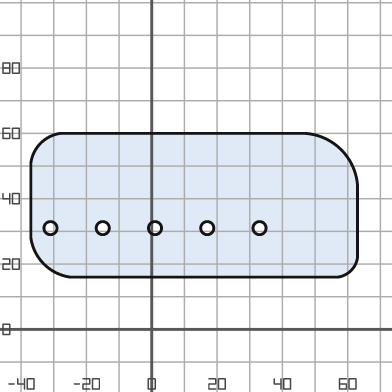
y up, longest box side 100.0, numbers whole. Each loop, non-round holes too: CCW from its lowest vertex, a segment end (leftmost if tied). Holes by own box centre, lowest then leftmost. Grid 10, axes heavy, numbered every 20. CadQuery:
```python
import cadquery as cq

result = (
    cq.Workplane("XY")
    .moveTo(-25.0, 16.0)
    .lineTo(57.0, 16.0)
    .threePointArc((61.0, 18.0), (63.0, 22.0))
    .lineTo(63.0, 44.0)
    .threePointArc((58.0, 55.0), (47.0, 60.0))
    .lineTo(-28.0, 60.0)
    .threePointArc((-34.0, 57.0), (-37.0, 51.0))
    .lineTo(-37.0, 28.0)
    .threePointArc((-33.0, 20.0), (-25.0, 16.0))
    .close()
    .moveTo(-31.0, 31.0)
    .circle(2.0)
    .moveTo(-15.0, 31.0)
    .circle(2.0)
    .moveTo(1.0, 31.0)
    .circle(2.0)
    .moveTo(17.0, 31.0)
    .circle(2.0)
    .moveTo(33.0, 31.0)
    .circle(2.0)
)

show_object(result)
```